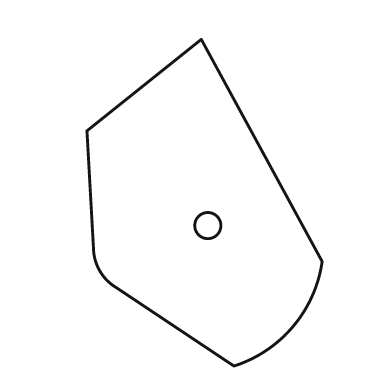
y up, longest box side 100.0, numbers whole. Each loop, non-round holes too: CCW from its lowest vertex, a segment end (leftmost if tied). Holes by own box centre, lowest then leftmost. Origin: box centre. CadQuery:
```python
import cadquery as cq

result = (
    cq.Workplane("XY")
    .moveTo(9.0, -50.0)
    .threePointArc((27.0, -38.0), (36.0, -18.0))
    .lineTo(-1.0, 50.0)
    .lineTo(-36.0, 22.0)
    .lineTo(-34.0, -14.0)
    .threePointArc((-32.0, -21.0), (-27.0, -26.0))
    .close()
    .moveTo(1.0, -7.0)
    .circle(4.0)
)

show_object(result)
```